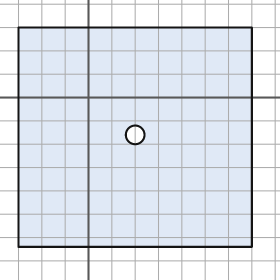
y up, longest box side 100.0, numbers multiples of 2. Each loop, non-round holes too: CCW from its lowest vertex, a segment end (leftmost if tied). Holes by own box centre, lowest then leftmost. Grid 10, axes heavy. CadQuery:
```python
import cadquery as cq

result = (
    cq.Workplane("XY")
    .moveTo(-30.0, -64.0)
    .lineTo(70.0, -64.0)
    .lineTo(70.0, 30.0)
    .lineTo(-30.0, 30.0)
    .close()
    .moveTo(20.0, -16.0)
    .circle(4.0)
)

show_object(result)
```